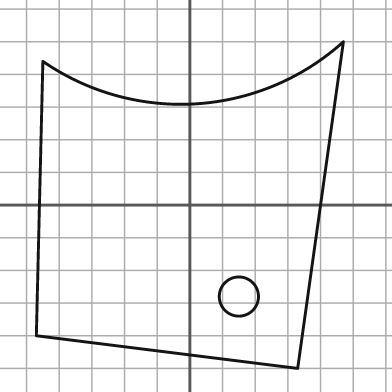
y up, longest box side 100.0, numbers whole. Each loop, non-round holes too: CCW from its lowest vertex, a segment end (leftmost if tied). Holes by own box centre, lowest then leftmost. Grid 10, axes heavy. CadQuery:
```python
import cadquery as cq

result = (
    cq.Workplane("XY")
    .moveTo(33.0, -50.0)
    .lineTo(47.0, 50.0)
    .threePointArc((2.0, 31.0), (-45.0, 44.0))
    .lineTo(-47.0, -40.0)
    .close()
    .moveTo(15.0, -28.0)
    .circle(6.0)
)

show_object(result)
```